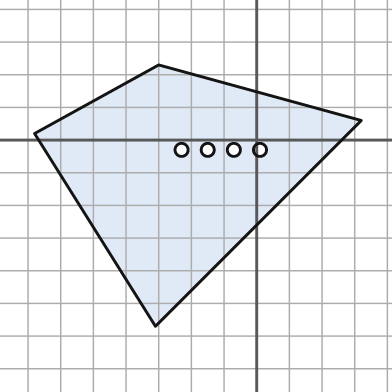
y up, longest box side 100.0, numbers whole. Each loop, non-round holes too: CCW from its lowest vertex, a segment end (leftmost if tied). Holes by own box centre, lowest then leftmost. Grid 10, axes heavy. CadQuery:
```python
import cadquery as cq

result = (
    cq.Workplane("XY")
    .moveTo(-31.0, -57.0)
    .lineTo(32.0, 6.0)
    .lineTo(-30.0, 23.0)
    .lineTo(-68.0, 2.0)
    .close()
    .moveTo(-23.0, -3.0)
    .circle(2.0)
    .moveTo(-15.0, -3.0)
    .circle(2.0)
    .moveTo(-7.0, -3.0)
    .circle(2.0)
    .moveTo(1.0, -3.0)
    .circle(2.0)
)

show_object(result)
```